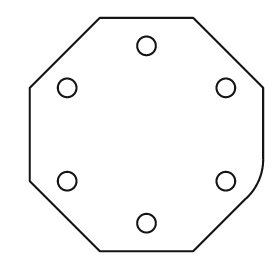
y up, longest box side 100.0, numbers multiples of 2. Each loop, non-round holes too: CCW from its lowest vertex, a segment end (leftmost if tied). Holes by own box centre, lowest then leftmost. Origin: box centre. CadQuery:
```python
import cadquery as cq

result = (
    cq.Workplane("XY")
    .moveTo(-20.0, -50.0)
    .lineTo(20.0, -50.0)
    .lineTo(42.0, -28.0)
    .threePointArc((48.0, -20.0), (50.0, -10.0))
    .lineTo(50.0, 20.0)
    .lineTo(20.0, 50.0)
    .lineTo(-20.0, 50.0)
    .lineTo(-50.0, 20.0)
    .lineTo(-50.0, -20.0)
    .close()
    .moveTo(0.0, -38.0)
    .circle(4.0)
    .moveTo(-34.0, -20.0)
    .circle(4.0)
    .moveTo(34.0, -20.0)
    .circle(4.0)
    .moveTo(-34.0, 20.0)
    .circle(4.0)
    .moveTo(34.0, 20.0)
    .circle(4.0)
    .moveTo(0.0, 38.0)
    .circle(4.0)
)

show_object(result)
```